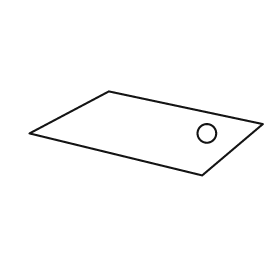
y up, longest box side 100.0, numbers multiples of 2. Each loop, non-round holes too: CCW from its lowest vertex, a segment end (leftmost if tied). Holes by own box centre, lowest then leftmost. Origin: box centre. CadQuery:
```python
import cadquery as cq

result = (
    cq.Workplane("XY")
    .moveTo(24.0, -18.0)
    .lineTo(50.0, 4.0)
    .lineTo(-16.0, 18.0)
    .lineTo(-50.0, 0.0)
    .close()
    .moveTo(26.0, 0.0)
    .circle(4.0)
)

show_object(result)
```